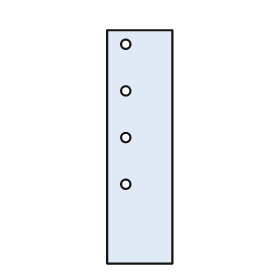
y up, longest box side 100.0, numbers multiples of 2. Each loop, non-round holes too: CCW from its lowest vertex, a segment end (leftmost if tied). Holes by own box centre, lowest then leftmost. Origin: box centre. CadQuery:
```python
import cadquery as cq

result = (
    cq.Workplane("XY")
    .moveTo(-14.0, -50.0)
    .lineTo(14.0, -50.0)
    .lineTo(14.0, 50.0)
    .lineTo(-14.0, 50.0)
    .close()
    .moveTo(-6.0, -16.0)
    .circle(2.0)
    .moveTo(-6.0, 4.0)
    .circle(2.0)
    .moveTo(-6.0, 24.0)
    .circle(2.0)
    .moveTo(-6.0, 44.0)
    .circle(2.0)
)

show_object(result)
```